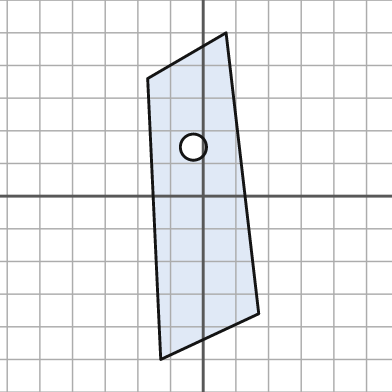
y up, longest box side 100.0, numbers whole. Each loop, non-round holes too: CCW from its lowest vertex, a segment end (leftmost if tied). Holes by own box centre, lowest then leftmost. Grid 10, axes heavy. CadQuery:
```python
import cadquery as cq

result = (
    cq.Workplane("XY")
    .moveTo(-13.0, -50.0)
    .lineTo(17.0, -36.0)
    .lineTo(7.0, 50.0)
    .lineTo(-17.0, 36.0)
    .close()
    .moveTo(-3.0, 15.0)
    .circle(4.0)
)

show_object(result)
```